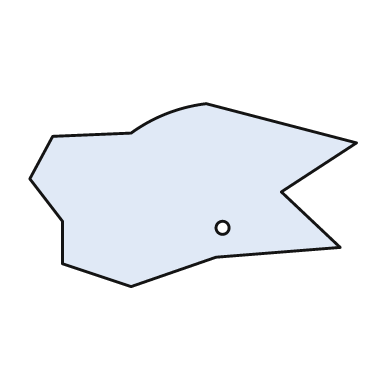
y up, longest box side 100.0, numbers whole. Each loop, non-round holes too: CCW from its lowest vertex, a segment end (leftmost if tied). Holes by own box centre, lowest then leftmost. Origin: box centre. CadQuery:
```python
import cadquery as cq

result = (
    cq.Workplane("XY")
    .moveTo(-19.0, -28.0)
    .lineTo(7.0, -19.0)
    .lineTo(45.0, -16.0)
    .lineTo(27.0, 1.0)
    .lineTo(50.0, 16.0)
    .lineTo(4.0, 28.0)
    .threePointArc((-8.0, 25.0), (-19.0, 19.0))
    .lineTo(-43.0, 18.0)
    .lineTo(-50.0, 5.0)
    .lineTo(-40.0, -8.0)
    .lineTo(-40.0, -21.0)
    .close()
    .moveTo(9.0, -10.0)
    .circle(2.0)
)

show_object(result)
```